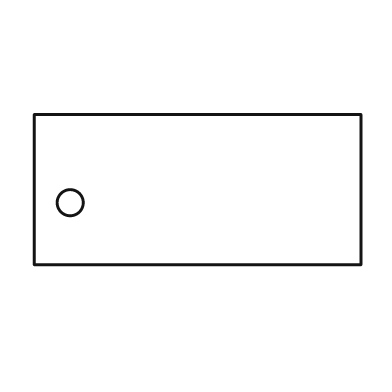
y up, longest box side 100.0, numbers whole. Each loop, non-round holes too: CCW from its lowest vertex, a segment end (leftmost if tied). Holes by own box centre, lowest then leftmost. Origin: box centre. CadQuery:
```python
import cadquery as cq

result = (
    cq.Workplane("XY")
    .moveTo(-50.0, -23.0)
    .lineTo(50.0, -23.0)
    .lineTo(50.0, 23.0)
    .lineTo(-50.0, 23.0)
    .close()
    .moveTo(-39.0, -4.0)
    .circle(4.0)
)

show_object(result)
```